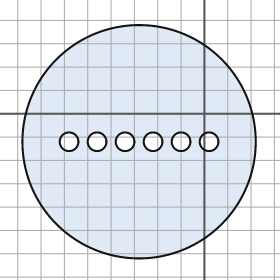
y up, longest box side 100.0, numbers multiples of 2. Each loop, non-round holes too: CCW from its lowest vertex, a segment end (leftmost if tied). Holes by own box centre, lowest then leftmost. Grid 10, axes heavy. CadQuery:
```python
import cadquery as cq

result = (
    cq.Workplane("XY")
    .moveTo(-28.0, -12.0)
    .circle(50.0)
    .moveTo(-58.0, -12.0)
    .circle(4.0)
    .moveTo(-46.0, -12.0)
    .circle(4.0)
    .moveTo(-34.0, -12.0)
    .circle(4.0)
    .moveTo(-22.0, -12.0)
    .circle(4.0)
    .moveTo(-10.0, -12.0)
    .circle(4.0)
    .moveTo(2.0, -12.0)
    .circle(4.0)
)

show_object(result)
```